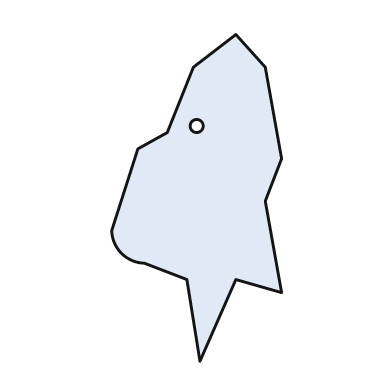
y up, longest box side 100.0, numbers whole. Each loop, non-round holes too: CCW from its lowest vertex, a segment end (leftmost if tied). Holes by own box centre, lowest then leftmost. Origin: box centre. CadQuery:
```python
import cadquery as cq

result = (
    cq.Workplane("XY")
    .moveTo(1.0, -50.0)
    .lineTo(12.0, -25.0)
    .lineTo(26.0, -29.0)
    .lineTo(21.0, -1.0)
    .lineTo(26.0, 12.0)
    .lineTo(21.0, 40.0)
    .lineTo(12.0, 50.0)
    .lineTo(-1.0, 40.0)
    .lineTo(-9.0, 20.0)
    .lineTo(-18.0, 15.0)
    .lineTo(-26.0, -10.0)
    .threePointArc((-23.0, -17.0), (-16.0, -20.0))
    .lineTo(-3.0, -25.0)
    .close()
    .moveTo(0.0, 22.0)
    .circle(2.0)
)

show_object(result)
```